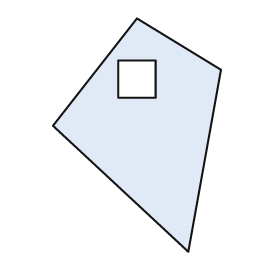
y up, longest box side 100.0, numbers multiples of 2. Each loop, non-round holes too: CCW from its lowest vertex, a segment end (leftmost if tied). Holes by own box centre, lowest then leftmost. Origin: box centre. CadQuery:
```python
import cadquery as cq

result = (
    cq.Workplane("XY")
    .moveTo(22.0, -50.0)
    .lineTo(36.0, 28.0)
    .lineTo(0.0, 50.0)
    .lineTo(-36.0, 4.0)
    .close()
    .moveTo(-8.0, 16.0)
    .lineTo(8.0, 16.0)
    .lineTo(8.0, 32.0)
    .lineTo(-8.0, 32.0)
    .close()
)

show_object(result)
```